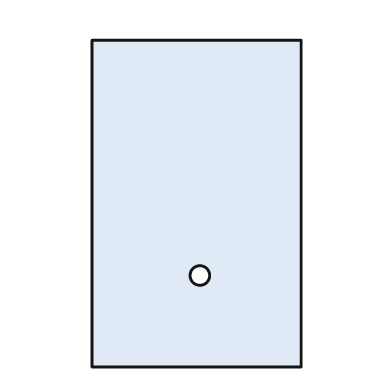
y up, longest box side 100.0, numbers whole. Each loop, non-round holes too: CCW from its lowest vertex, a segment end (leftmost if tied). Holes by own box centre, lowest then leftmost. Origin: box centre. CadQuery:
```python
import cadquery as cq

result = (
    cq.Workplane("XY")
    .moveTo(-32.0, -50.0)
    .lineTo(32.0, -50.0)
    .lineTo(32.0, 50.0)
    .lineTo(-32.0, 50.0)
    .close()
    .moveTo(1.0, -22.0)
    .circle(3.0)
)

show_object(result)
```